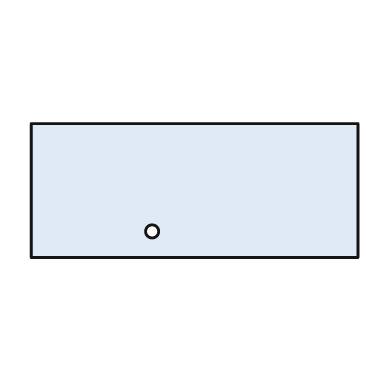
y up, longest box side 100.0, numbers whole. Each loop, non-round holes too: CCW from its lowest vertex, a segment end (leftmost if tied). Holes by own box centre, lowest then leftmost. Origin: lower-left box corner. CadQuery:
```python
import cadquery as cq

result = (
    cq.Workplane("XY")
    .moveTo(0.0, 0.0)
    .lineTo(100.0, 0.0)
    .lineTo(100.0, 41.0)
    .lineTo(0.0, 41.0)
    .close()
    .moveTo(37.0, 8.0)
    .circle(2.0)
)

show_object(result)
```